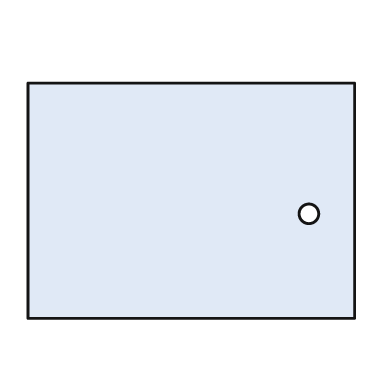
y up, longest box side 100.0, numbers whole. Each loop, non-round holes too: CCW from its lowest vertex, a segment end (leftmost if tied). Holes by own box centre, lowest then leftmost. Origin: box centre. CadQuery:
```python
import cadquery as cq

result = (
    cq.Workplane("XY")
    .moveTo(-50.0, -36.0)
    .lineTo(50.0, -36.0)
    .lineTo(50.0, 36.0)
    .lineTo(-50.0, 36.0)
    .close()
    .moveTo(36.0, -4.0)
    .circle(3.0)
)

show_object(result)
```